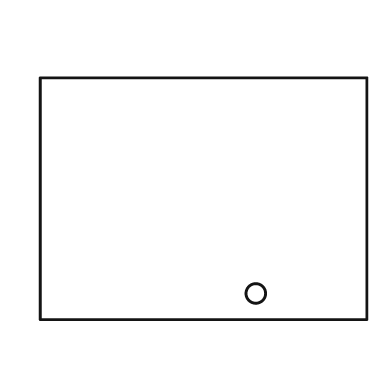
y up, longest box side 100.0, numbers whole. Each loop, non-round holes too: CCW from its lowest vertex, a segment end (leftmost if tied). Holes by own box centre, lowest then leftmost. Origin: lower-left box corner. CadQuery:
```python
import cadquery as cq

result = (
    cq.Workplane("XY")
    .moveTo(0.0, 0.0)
    .lineTo(100.0, 0.0)
    .lineTo(100.0, 74.0)
    .lineTo(0.0, 74.0)
    .close()
    .moveTo(66.0, 8.0)
    .circle(3.0)
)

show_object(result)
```